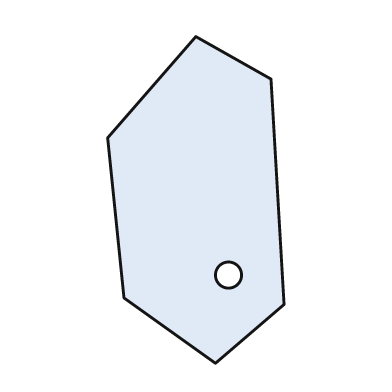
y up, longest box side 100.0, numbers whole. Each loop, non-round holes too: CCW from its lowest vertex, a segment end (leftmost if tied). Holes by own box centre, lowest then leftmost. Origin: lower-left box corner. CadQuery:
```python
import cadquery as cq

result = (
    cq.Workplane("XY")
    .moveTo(33.0, 0.0)
    .lineTo(54.0, 18.0)
    .lineTo(50.0, 87.0)
    .lineTo(27.0, 100.0)
    .lineTo(0.0, 69.0)
    .lineTo(5.0, 20.0)
    .close()
    .moveTo(37.0, 27.0)
    .circle(4.0)
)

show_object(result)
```